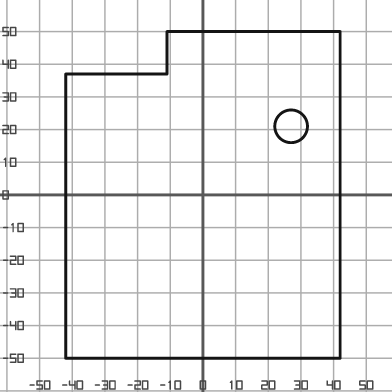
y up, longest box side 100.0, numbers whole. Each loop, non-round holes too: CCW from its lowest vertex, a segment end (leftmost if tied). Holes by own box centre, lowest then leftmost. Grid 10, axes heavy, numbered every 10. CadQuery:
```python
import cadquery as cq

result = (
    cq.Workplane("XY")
    .moveTo(-42.0, -50.0)
    .lineTo(42.0, -50.0)
    .lineTo(42.0, 50.0)
    .lineTo(-11.0, 50.0)
    .lineTo(-11.0, 37.0)
    .lineTo(-42.0, 37.0)
    .close()
    .moveTo(27.0, 21.0)
    .circle(5.0)
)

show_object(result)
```